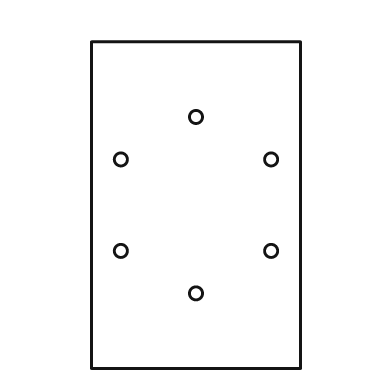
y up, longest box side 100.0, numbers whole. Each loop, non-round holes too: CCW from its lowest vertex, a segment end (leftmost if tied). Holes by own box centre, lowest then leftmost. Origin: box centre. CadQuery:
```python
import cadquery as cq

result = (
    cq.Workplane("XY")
    .moveTo(-32.0, -50.0)
    .lineTo(32.0, -50.0)
    .lineTo(32.0, 50.0)
    .lineTo(-32.0, 50.0)
    .close()
    .moveTo(0.0, -27.0)
    .circle(2.0)
    .moveTo(-23.0, -14.0)
    .circle(2.0)
    .moveTo(23.0, -14.0)
    .circle(2.0)
    .moveTo(-23.0, 14.0)
    .circle(2.0)
    .moveTo(23.0, 14.0)
    .circle(2.0)
    .moveTo(0.0, 27.0)
    .circle(2.0)
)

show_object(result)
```